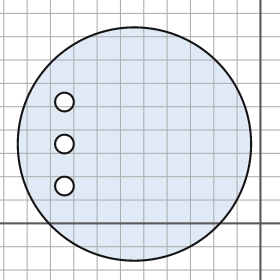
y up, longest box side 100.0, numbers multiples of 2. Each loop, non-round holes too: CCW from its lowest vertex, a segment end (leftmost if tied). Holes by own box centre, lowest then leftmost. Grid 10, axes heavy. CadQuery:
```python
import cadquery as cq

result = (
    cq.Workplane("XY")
    .moveTo(-54.0, 34.0)
    .circle(50.0)
    .moveTo(-84.0, 16.0)
    .circle(4.0)
    .moveTo(-84.0, 34.0)
    .circle(4.0)
    .moveTo(-84.0, 52.0)
    .circle(4.0)
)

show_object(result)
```